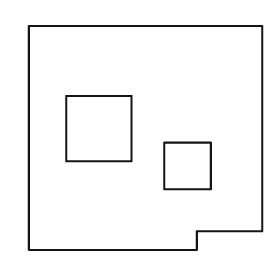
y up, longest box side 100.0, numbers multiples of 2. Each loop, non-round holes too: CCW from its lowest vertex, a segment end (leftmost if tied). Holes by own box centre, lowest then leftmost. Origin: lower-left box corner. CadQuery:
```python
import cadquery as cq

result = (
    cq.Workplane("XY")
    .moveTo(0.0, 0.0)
    .lineTo(72.0, 0.0)
    .lineTo(72.0, 8.0)
    .lineTo(100.0, 8.0)
    .lineTo(100.0, 96.0)
    .lineTo(0.0, 96.0)
    .close()
    .moveTo(58.0, 26.0)
    .lineTo(78.0, 26.0)
    .lineTo(78.0, 46.0)
    .lineTo(58.0, 46.0)
    .close()
    .moveTo(16.0, 38.0)
    .lineTo(44.0, 38.0)
    .lineTo(44.0, 66.0)
    .lineTo(16.0, 66.0)
    .close()
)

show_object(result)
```